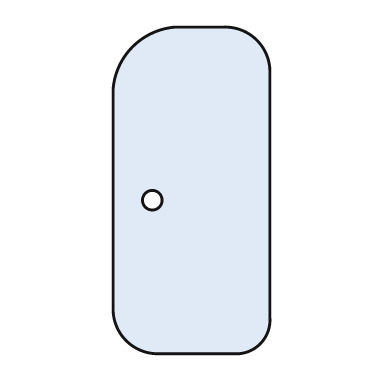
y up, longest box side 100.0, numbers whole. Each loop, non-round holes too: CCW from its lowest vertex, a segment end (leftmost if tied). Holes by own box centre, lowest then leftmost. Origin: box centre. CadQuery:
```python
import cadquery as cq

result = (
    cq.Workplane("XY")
    .moveTo(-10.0, -50.0)
    .lineTo(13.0, -50.0)
    .threePointArc((21.0, -47.0), (24.0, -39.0))
    .lineTo(24.0, 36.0)
    .threePointArc((20.0, 46.0), (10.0, 50.0))
    .lineTo(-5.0, 50.0)
    .threePointArc((-18.0, 44.0), (-24.0, 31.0))
    .lineTo(-24.0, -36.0)
    .threePointArc((-20.0, -46.0), (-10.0, -50.0))
    .close()
    .moveTo(-12.0, -3.0)
    .circle(3.0)
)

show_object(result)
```